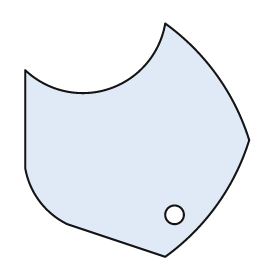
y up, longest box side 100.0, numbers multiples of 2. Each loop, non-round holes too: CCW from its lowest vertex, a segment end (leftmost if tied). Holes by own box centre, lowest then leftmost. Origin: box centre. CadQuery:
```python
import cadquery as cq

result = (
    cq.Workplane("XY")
    .moveTo(12.0, -50.0)
    .threePointArc((34.0, -28.0), (48.0, 0.0))
    .threePointArc((34.0, 28.0), (12.0, 50.0))
    .threePointArc((-12.0, 22.0), (-48.0, 30.0))
    .lineTo(-48.0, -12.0)
    .threePointArc((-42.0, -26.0), (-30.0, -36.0))
    .close()
    .moveTo(16.0, -32.0)
    .circle(4.0)
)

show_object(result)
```